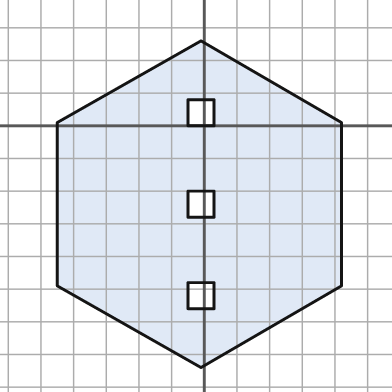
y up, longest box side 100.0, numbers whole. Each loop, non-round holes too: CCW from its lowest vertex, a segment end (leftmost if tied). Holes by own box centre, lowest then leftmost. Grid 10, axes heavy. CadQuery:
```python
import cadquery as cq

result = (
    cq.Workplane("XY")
    .moveTo(-1.0, -74.0)
    .lineTo(42.0, -49.0)
    .lineTo(42.0, 1.0)
    .lineTo(-1.0, 26.0)
    .lineTo(-45.0, 1.0)
    .lineTo(-45.0, -49.0)
    .close()
    .moveTo(-5.0, -56.0)
    .lineTo(3.0, -56.0)
    .lineTo(3.0, -48.0)
    .lineTo(-5.0, -48.0)
    .close()
    .moveTo(-5.0, -28.0)
    .lineTo(3.0, -28.0)
    .lineTo(3.0, -20.0)
    .lineTo(-5.0, -20.0)
    .close()
    .moveTo(-5.0, 0.0)
    .lineTo(3.0, 0.0)
    .lineTo(3.0, 8.0)
    .lineTo(-5.0, 8.0)
    .close()
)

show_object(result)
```